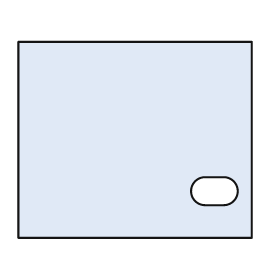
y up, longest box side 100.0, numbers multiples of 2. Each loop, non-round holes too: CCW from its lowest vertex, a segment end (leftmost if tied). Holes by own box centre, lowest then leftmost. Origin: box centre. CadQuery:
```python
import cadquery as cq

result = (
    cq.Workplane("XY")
    .moveTo(-50.0, -42.0)
    .lineTo(50.0, -42.0)
    .lineTo(50.0, 42.0)
    .lineTo(-50.0, 42.0)
    .close()
    .moveTo(30.0, -28.0)
    .lineTo(38.0, -28.0)
    .threePointArc((44.0, -22.0), (38.0, -16.0))
    .lineTo(30.0, -16.0)
    .threePointArc((24.0, -22.0), (30.0, -28.0))
    .close()
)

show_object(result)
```